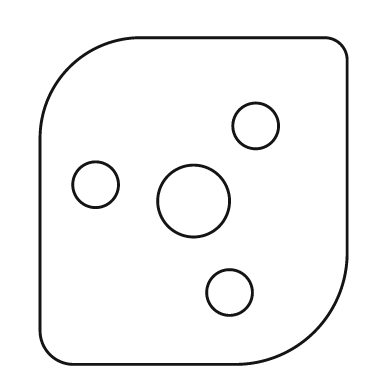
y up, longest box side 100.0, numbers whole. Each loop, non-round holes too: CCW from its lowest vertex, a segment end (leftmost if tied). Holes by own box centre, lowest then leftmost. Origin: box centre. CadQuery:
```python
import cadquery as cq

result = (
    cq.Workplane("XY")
    .moveTo(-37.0, -50.0)
    .lineTo(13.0, -50.0)
    .threePointArc((37.0, -40.0), (47.0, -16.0))
    .lineTo(47.0, 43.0)
    .threePointArc((45.0, 48.0), (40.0, 50.0))
    .lineTo(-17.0, 50.0)
    .threePointArc((-38.0, 41.0), (-47.0, 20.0))
    .lineTo(-47.0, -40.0)
    .threePointArc((-44.0, -47.0), (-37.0, -50.0))
    .close()
    .moveTo(11.0, -28.0)
    .circle(7.0)
    .moveTo(0.0, 0.0)
    .circle(11.0)
    .moveTo(-30.0, 5.0)
    .circle(7.0)
    .moveTo(19.0, 23.0)
    .circle(7.0)
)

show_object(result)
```